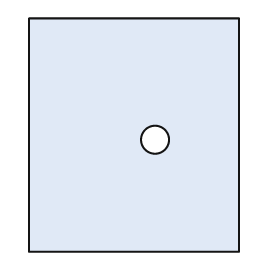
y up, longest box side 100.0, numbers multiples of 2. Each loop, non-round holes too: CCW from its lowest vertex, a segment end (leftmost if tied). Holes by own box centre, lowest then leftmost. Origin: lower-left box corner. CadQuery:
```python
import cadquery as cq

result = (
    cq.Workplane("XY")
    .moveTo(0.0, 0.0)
    .lineTo(90.0, 0.0)
    .lineTo(90.0, 100.0)
    .lineTo(0.0, 100.0)
    .close()
    .moveTo(54.0, 48.0)
    .circle(6.0)
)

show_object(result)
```